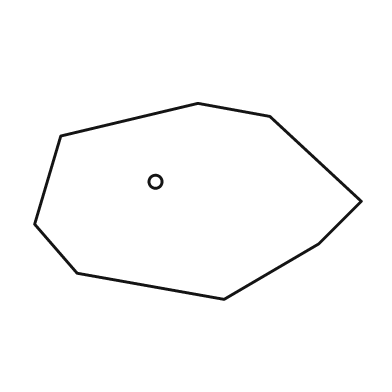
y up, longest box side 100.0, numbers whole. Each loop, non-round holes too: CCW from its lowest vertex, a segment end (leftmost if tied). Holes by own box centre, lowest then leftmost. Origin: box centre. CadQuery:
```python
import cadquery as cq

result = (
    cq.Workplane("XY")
    .moveTo(8.0, -30.0)
    .lineTo(37.0, -13.0)
    .lineTo(50.0, 0.0)
    .lineTo(22.0, 26.0)
    .lineTo(0.0, 30.0)
    .lineTo(-42.0, 20.0)
    .lineTo(-50.0, -7.0)
    .lineTo(-37.0, -22.0)
    .close()
    .moveTo(-13.0, 6.0)
    .circle(2.0)
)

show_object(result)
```